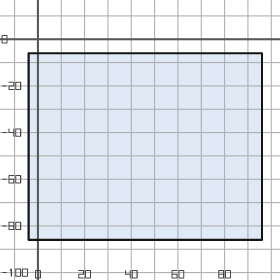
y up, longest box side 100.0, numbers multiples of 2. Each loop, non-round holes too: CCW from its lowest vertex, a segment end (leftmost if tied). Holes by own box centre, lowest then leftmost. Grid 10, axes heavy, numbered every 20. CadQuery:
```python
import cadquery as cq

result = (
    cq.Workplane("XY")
    .moveTo(-4.0, -86.0)
    .lineTo(96.0, -86.0)
    .lineTo(96.0, -6.0)
    .lineTo(-4.0, -6.0)
    .close()
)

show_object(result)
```